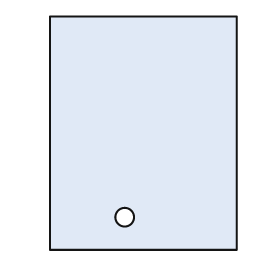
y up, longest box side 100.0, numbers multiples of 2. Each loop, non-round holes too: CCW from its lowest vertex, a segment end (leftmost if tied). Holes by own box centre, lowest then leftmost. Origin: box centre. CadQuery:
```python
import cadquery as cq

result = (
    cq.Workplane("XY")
    .moveTo(-40.0, -50.0)
    .lineTo(40.0, -50.0)
    .lineTo(40.0, 50.0)
    .lineTo(-40.0, 50.0)
    .close()
    .moveTo(-8.0, -36.0)
    .circle(4.0)
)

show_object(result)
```